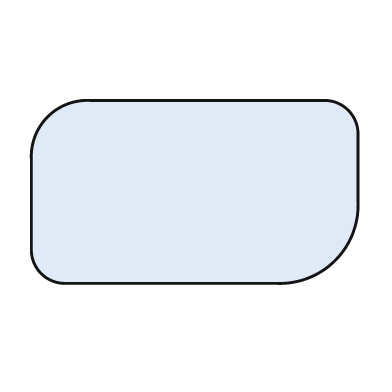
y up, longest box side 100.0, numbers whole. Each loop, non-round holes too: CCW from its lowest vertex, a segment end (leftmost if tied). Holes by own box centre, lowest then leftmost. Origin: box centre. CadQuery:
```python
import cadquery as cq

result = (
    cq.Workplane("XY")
    .moveTo(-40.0, -28.0)
    .lineTo(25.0, -28.0)
    .threePointArc((43.0, -21.0), (50.0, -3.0))
    .lineTo(50.0, 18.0)
    .threePointArc((47.0, 25.0), (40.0, 28.0))
    .lineTo(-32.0, 28.0)
    .threePointArc((-45.0, 23.0), (-50.0, 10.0))
    .lineTo(-50.0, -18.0)
    .threePointArc((-47.0, -25.0), (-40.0, -28.0))
    .close()
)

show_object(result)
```